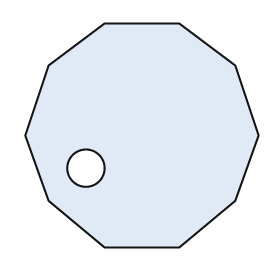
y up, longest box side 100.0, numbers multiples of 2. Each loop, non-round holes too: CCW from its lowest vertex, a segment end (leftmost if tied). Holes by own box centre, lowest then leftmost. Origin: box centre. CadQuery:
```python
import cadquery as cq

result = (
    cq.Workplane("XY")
    .moveTo(-16.0, -48.0)
    .lineTo(16.0, -48.0)
    .lineTo(40.0, -28.0)
    .lineTo(50.0, 0.0)
    .lineTo(40.0, 30.0)
    .lineTo(16.0, 48.0)
    .lineTo(-16.0, 48.0)
    .lineTo(-40.0, 30.0)
    .lineTo(-50.0, 0.0)
    .lineTo(-40.0, -28.0)
    .close()
    .moveTo(-24.0, -14.0)
    .circle(8.0)
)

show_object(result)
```